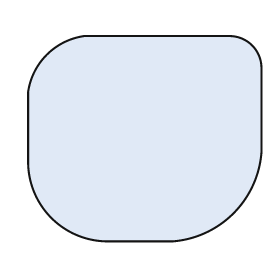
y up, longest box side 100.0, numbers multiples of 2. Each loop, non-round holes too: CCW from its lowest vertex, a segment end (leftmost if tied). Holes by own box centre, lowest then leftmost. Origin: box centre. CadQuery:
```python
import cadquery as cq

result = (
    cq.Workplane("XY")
    .moveTo(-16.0, -44.0)
    .lineTo(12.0, -44.0)
    .threePointArc((38.0, -32.0), (50.0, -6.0))
    .lineTo(50.0, 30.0)
    .threePointArc((46.0, 40.0), (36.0, 44.0))
    .lineTo(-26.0, 44.0)
    .threePointArc((-42.0, 36.0), (-50.0, 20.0))
    .lineTo(-50.0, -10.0)
    .threePointArc((-40.0, -34.0), (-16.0, -44.0))
    .close()
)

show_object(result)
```